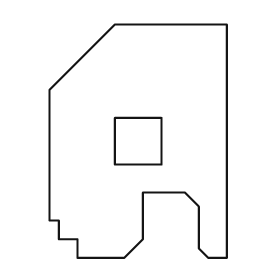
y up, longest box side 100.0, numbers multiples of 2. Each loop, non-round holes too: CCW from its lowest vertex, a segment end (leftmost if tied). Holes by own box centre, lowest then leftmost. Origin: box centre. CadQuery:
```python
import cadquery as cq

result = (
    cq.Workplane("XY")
    .moveTo(-26.0, -50.0)
    .lineTo(-6.0, -50.0)
    .lineTo(2.0, -42.0)
    .lineTo(2.0, -22.0)
    .lineTo(20.0, -22.0)
    .lineTo(26.0, -28.0)
    .lineTo(26.0, -46.0)
    .lineTo(30.0, -50.0)
    .lineTo(38.0, -50.0)
    .lineTo(38.0, 50.0)
    .lineTo(-10.0, 50.0)
    .lineTo(-38.0, 22.0)
    .lineTo(-38.0, -34.0)
    .lineTo(-34.0, -34.0)
    .lineTo(-34.0, -42.0)
    .lineTo(-26.0, -42.0)
    .close()
    .moveTo(-10.0, -10.0)
    .lineTo(10.0, -10.0)
    .lineTo(10.0, 10.0)
    .lineTo(-10.0, 10.0)
    .close()
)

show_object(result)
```